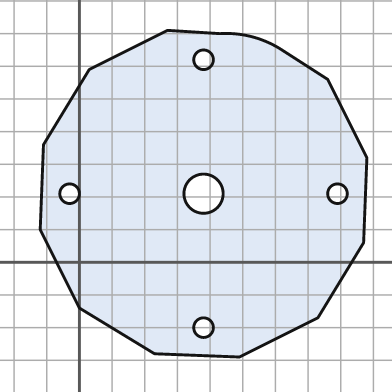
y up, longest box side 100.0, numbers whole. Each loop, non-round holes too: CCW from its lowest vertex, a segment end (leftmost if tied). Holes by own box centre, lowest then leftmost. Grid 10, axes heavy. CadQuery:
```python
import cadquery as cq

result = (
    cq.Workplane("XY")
    .moveTo(49.0, -29.0)
    .lineTo(73.0, -17.0)
    .lineTo(87.0, 6.0)
    .lineTo(88.0, 32.0)
    .lineTo(76.0, 56.0)
    .lineTo(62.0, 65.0)
    .threePointArc((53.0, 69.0), (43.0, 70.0))
    .lineTo(27.0, 71.0)
    .lineTo(3.0, 59.0)
    .lineTo(-11.0, 36.0)
    .lineTo(-12.0, 10.0)
    .lineTo(0.0, -14.0)
    .lineTo(23.0, -28.0)
    .close()
    .moveTo(38.0, -20.0)
    .circle(3.0)
    .moveTo(-3.0, 21.0)
    .circle(3.0)
    .moveTo(38.0, 21.0)
    .circle(6.0)
    .moveTo(79.0, 21.0)
    .circle(3.0)
    .moveTo(38.0, 62.0)
    .circle(3.0)
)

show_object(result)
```